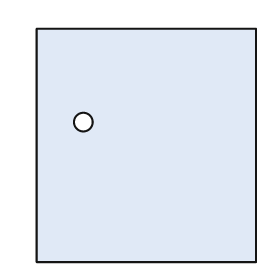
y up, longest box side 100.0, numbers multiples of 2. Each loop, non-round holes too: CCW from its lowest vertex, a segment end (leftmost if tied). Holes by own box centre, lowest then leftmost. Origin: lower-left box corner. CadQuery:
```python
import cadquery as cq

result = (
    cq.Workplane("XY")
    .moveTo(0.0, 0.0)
    .lineTo(94.0, 0.0)
    .lineTo(94.0, 100.0)
    .lineTo(0.0, 100.0)
    .close()
    .moveTo(20.0, 60.0)
    .circle(4.0)
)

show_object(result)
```